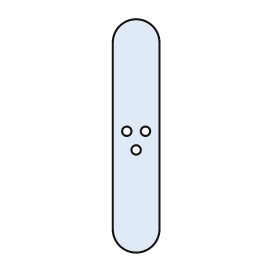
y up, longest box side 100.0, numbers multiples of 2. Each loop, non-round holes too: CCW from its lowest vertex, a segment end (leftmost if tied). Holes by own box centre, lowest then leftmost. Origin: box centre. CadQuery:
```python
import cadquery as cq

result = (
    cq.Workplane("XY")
    .moveTo(-10.0, -40.0)
    .threePointArc((0.0, -50.0), (10.0, -40.0))
    .lineTo(10.0, 40.0)
    .threePointArc((0.0, 50.0), (-10.0, 40.0))
    .close()
    .moveTo(0.0, -6.0)
    .circle(2.0)
    .moveTo(-4.0, 2.0)
    .circle(2.0)
    .moveTo(4.0, 2.0)
    .circle(2.0)
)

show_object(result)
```